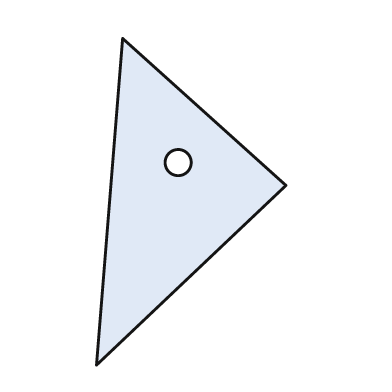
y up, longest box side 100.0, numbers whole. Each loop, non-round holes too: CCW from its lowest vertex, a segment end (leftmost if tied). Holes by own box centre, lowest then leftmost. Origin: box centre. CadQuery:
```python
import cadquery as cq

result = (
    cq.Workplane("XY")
    .moveTo(-29.0, -50.0)
    .lineTo(29.0, 5.0)
    .lineTo(-21.0, 50.0)
    .close()
    .moveTo(-4.0, 12.0)
    .circle(4.0)
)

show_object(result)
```